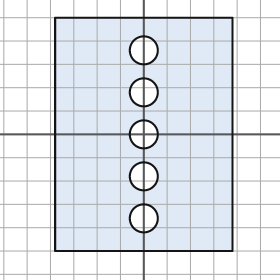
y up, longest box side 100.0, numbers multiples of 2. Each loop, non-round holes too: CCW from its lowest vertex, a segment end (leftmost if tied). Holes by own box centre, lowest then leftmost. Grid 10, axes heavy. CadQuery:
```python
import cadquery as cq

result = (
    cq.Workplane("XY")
    .moveTo(-38.0, -50.0)
    .lineTo(38.0, -50.0)
    .lineTo(38.0, 50.0)
    .lineTo(-38.0, 50.0)
    .close()
    .moveTo(0.0, -36.0)
    .circle(6.0)
    .moveTo(0.0, -18.0)
    .circle(6.0)
    .moveTo(0.0, 0.0)
    .circle(6.0)
    .moveTo(0.0, 18.0)
    .circle(6.0)
    .moveTo(0.0, 36.0)
    .circle(6.0)
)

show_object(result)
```